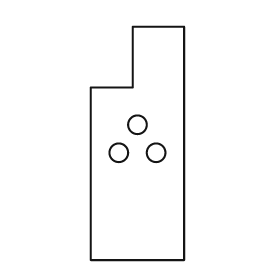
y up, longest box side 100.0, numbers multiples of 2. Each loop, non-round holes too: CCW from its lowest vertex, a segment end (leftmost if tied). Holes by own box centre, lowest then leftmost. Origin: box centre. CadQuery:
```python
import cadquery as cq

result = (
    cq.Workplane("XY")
    .moveTo(-20.0, -50.0)
    .lineTo(20.0, -50.0)
    .lineTo(20.0, 50.0)
    .lineTo(-2.0, 50.0)
    .lineTo(-2.0, 24.0)
    .lineTo(-20.0, 24.0)
    .close()
    .moveTo(-8.0, -4.0)
    .circle(4.0)
    .moveTo(8.0, -4.0)
    .circle(4.0)
    .moveTo(0.0, 8.0)
    .circle(4.0)
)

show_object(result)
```